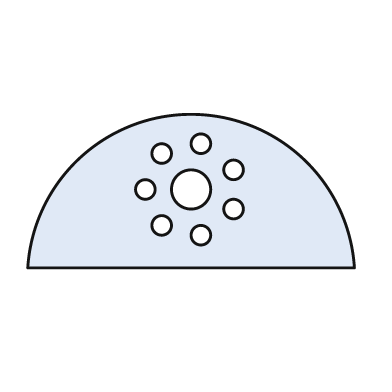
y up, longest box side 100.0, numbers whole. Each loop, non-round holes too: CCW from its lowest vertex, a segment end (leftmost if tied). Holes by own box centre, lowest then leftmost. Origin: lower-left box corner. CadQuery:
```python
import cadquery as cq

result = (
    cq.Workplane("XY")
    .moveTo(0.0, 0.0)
    .lineTo(100.0, 0.0)
    .threePointArc((50.0, 47.0), (0.0, 0.0))
    .close()
    .moveTo(53.0, 10.0)
    .circle(3.0)
    .moveTo(41.0, 13.0)
    .circle(3.0)
    .moveTo(63.0, 18.0)
    .circle(3.0)
    .moveTo(36.0, 24.0)
    .circle(3.0)
    .moveTo(50.0, 24.0)
    .circle(6.0)
    .moveTo(63.0, 30.0)
    .circle(3.0)
    .moveTo(41.0, 35.0)
    .circle(3.0)
    .moveTo(53.0, 38.0)
    .circle(3.0)
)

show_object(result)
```